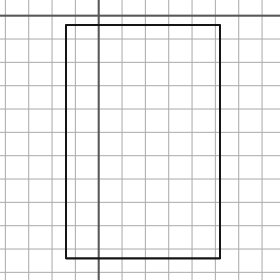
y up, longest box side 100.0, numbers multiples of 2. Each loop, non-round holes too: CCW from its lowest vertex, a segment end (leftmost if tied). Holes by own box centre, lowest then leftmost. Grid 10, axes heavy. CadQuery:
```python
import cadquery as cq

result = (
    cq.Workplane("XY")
    .moveTo(-14.0, -104.0)
    .lineTo(52.0, -104.0)
    .lineTo(52.0, -4.0)
    .lineTo(-14.0, -4.0)
    .close()
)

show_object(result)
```